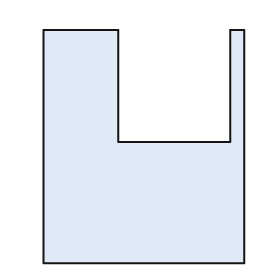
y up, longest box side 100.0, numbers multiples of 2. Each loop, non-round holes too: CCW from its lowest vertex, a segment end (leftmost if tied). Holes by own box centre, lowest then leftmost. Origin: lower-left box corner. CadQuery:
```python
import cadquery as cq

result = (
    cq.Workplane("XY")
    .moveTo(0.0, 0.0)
    .lineTo(86.0, 0.0)
    .lineTo(86.0, 100.0)
    .lineTo(80.0, 100.0)
    .lineTo(80.0, 52.0)
    .lineTo(32.0, 52.0)
    .lineTo(32.0, 100.0)
    .lineTo(0.0, 100.0)
    .close()
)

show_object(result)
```